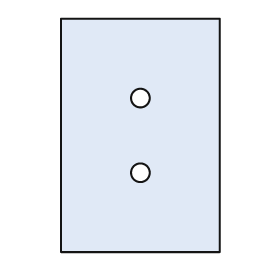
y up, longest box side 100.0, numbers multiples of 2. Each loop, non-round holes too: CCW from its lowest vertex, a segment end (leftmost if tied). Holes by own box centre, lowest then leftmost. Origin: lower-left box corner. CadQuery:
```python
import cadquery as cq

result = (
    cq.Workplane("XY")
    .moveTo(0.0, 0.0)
    .lineTo(68.0, 0.0)
    .lineTo(68.0, 100.0)
    .lineTo(0.0, 100.0)
    .close()
    .moveTo(34.0, 34.0)
    .circle(4.0)
    .moveTo(34.0, 66.0)
    .circle(4.0)
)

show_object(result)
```